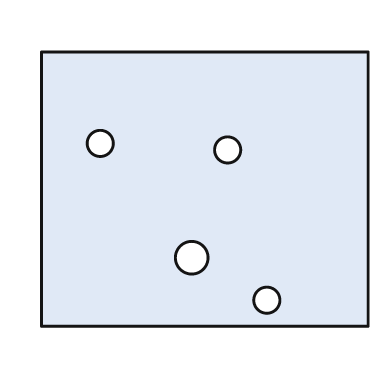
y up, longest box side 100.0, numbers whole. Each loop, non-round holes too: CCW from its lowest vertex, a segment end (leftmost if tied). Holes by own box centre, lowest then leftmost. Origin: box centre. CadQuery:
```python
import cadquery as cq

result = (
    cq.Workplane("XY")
    .moveTo(-50.0, -42.0)
    .lineTo(50.0, -42.0)
    .lineTo(50.0, 42.0)
    .lineTo(-50.0, 42.0)
    .close()
    .moveTo(19.0, -34.0)
    .circle(4.0)
    .moveTo(-4.0, -21.0)
    .circle(5.0)
    .moveTo(7.0, 12.0)
    .circle(4.0)
    .moveTo(-32.0, 14.0)
    .circle(4.0)
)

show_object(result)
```